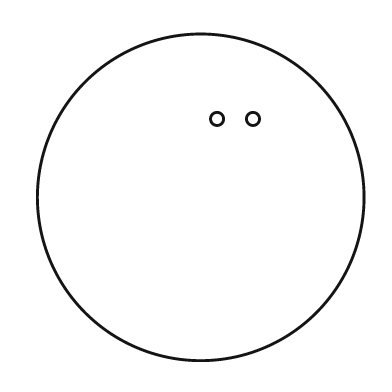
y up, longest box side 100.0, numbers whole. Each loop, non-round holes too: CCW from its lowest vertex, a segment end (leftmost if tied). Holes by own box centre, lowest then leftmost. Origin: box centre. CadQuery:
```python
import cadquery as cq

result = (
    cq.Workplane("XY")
    .moveTo(0.0, 0.0)
    .circle(50.0)
    .moveTo(5.0, 24.0)
    .circle(2.0)
    .moveTo(16.0, 24.0)
    .circle(2.0)
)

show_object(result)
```